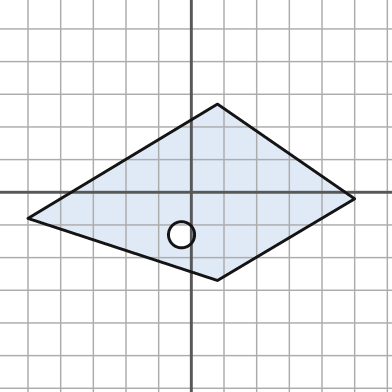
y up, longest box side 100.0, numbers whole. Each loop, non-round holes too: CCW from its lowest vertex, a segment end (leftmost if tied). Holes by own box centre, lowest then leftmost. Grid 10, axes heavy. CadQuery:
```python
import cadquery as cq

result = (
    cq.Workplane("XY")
    .moveTo(8.0, -27.0)
    .lineTo(50.0, -2.0)
    .lineTo(8.0, 27.0)
    .lineTo(-50.0, -8.0)
    .close()
    .moveTo(-3.0, -13.0)
    .circle(4.0)
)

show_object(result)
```